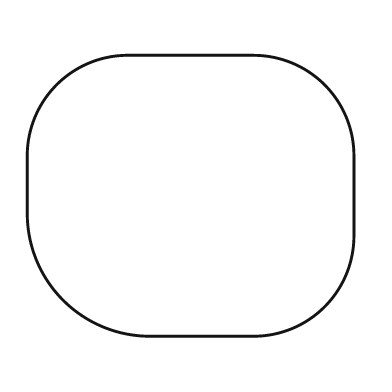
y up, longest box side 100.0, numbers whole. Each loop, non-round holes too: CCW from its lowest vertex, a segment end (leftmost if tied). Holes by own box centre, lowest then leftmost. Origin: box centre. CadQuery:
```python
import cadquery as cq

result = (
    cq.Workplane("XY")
    .moveTo(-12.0, -43.0)
    .lineTo(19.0, -43.0)
    .threePointArc((41.0, -34.0), (50.0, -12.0))
    .lineTo(50.0, 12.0)
    .threePointArc((41.0, 34.0), (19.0, 43.0))
    .lineTo(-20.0, 43.0)
    .threePointArc((-41.0, 34.0), (-50.0, 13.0))
    .lineTo(-50.0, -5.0)
    .threePointArc((-39.0, -32.0), (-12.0, -43.0))
    .close()
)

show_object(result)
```